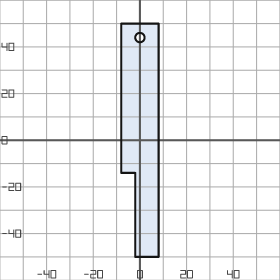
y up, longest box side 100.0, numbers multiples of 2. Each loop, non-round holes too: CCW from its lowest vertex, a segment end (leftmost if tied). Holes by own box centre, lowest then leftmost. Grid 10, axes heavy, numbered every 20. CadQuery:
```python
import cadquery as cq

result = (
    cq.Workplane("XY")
    .moveTo(-2.0, -50.0)
    .lineTo(8.0, -50.0)
    .lineTo(8.0, 50.0)
    .lineTo(-8.0, 50.0)
    .lineTo(-8.0, -14.0)
    .lineTo(-2.0, -14.0)
    .close()
    .moveTo(0.0, 44.0)
    .circle(2.0)
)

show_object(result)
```